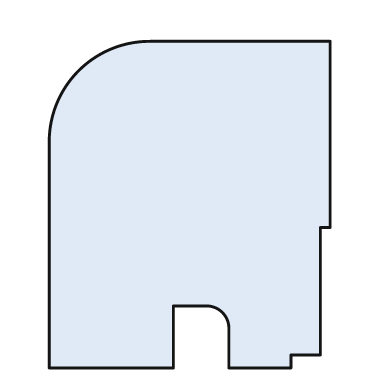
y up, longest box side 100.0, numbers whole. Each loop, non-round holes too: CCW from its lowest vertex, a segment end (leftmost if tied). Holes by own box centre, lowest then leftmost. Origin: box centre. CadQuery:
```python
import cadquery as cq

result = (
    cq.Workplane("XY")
    .moveTo(-43.0, -50.0)
    .lineTo(-5.0, -50.0)
    .lineTo(-5.0, -31.0)
    .lineTo(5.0, -31.0)
    .threePointArc((10.0, -33.0), (12.0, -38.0))
    .lineTo(12.0, -50.0)
    .lineTo(31.0, -50.0)
    .lineTo(31.0, -46.0)
    .lineTo(40.0, -46.0)
    .lineTo(40.0, -7.0)
    .lineTo(43.0, -7.0)
    .lineTo(43.0, 50.0)
    .lineTo(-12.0, 50.0)
    .threePointArc((-34.0, 41.0), (-43.0, 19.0))
    .close()
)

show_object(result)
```